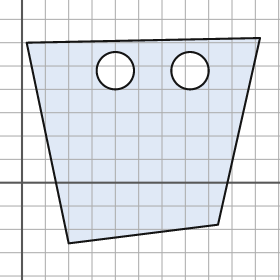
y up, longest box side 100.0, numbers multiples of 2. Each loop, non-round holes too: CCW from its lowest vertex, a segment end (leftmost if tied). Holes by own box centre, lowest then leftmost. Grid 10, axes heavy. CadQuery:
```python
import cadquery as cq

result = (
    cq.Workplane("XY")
    .moveTo(20.0, -26.0)
    .lineTo(84.0, -18.0)
    .lineTo(102.0, 62.0)
    .lineTo(2.0, 60.0)
    .close()
    .moveTo(40.0, 48.0)
    .circle(8.0)
    .moveTo(72.0, 48.0)
    .circle(8.0)
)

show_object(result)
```